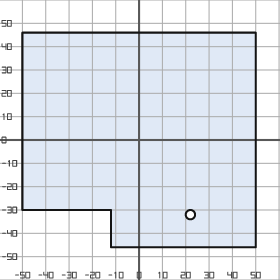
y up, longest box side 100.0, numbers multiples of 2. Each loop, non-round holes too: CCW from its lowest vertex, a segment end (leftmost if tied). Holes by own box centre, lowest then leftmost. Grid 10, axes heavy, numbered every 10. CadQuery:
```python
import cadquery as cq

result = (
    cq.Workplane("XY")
    .moveTo(-12.0, -46.0)
    .lineTo(50.0, -46.0)
    .lineTo(50.0, 46.0)
    .lineTo(-50.0, 46.0)
    .lineTo(-50.0, -30.0)
    .lineTo(-12.0, -30.0)
    .close()
    .moveTo(22.0, -32.0)
    .circle(2.0)
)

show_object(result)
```